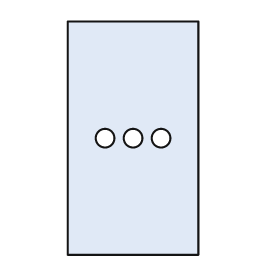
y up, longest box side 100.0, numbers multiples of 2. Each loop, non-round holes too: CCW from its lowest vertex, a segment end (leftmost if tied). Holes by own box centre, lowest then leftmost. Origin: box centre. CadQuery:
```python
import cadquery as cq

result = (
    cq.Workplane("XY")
    .moveTo(-28.0, -50.0)
    .lineTo(28.0, -50.0)
    .lineTo(28.0, 50.0)
    .lineTo(-28.0, 50.0)
    .close()
    .moveTo(-12.0, 0.0)
    .circle(4.0)
    .moveTo(0.0, 0.0)
    .circle(4.0)
    .moveTo(12.0, 0.0)
    .circle(4.0)
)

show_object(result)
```